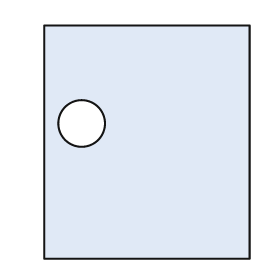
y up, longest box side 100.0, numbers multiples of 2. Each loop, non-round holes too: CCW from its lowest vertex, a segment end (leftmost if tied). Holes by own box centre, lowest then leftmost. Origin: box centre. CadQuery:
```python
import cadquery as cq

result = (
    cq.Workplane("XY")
    .moveTo(-44.0, -50.0)
    .lineTo(44.0, -50.0)
    .lineTo(44.0, 50.0)
    .lineTo(-44.0, 50.0)
    .close()
    .moveTo(-28.0, 8.0)
    .circle(10.0)
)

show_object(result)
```